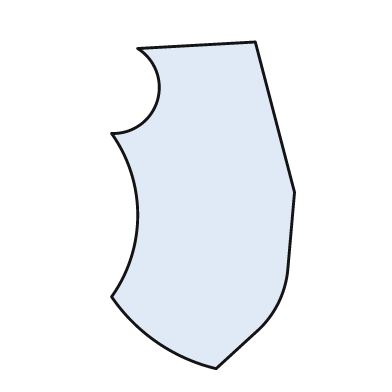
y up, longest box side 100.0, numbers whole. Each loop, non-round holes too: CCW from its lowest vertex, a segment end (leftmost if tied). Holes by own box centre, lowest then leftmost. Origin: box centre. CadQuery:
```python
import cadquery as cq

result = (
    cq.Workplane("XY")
    .moveTo(4.0, -50.0)
    .lineTo(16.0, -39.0)
    .threePointArc((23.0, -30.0), (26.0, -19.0))
    .lineTo(28.0, 4.0)
    .lineTo(16.0, 50.0)
    .lineTo(-20.0, 48.0)
    .threePointArc((-14.0, 32.0), (-28.0, 22.0))
    .threePointArc((-20.0, -3.0), (-28.0, -28.0))
    .threePointArc((-14.0, -42.0), (4.0, -50.0))
    .close()
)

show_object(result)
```